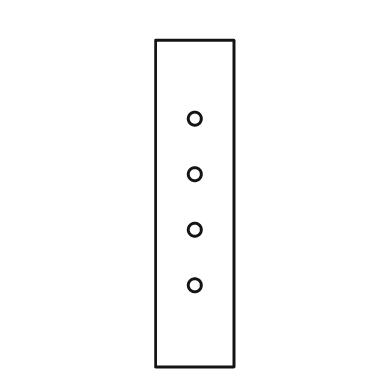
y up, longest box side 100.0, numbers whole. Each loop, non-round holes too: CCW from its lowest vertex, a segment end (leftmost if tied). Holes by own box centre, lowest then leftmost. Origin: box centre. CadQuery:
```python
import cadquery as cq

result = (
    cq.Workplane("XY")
    .moveTo(-12.0, -50.0)
    .lineTo(12.0, -50.0)
    .lineTo(12.0, 50.0)
    .lineTo(-12.0, 50.0)
    .close()
    .moveTo(0.0, -25.0)
    .circle(2.0)
    .moveTo(0.0, -8.0)
    .circle(2.0)
    .moveTo(0.0, 9.0)
    .circle(2.0)
    .moveTo(0.0, 26.0)
    .circle(2.0)
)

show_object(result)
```